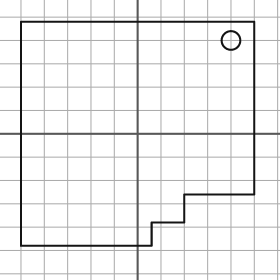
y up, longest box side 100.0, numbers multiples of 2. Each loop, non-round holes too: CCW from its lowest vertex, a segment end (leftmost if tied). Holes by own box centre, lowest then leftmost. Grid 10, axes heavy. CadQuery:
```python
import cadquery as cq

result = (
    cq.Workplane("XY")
    .moveTo(-50.0, -48.0)
    .lineTo(6.0, -48.0)
    .lineTo(6.0, -38.0)
    .lineTo(20.0, -38.0)
    .lineTo(20.0, -26.0)
    .lineTo(50.0, -26.0)
    .lineTo(50.0, 48.0)
    .lineTo(-50.0, 48.0)
    .close()
    .moveTo(40.0, 40.0)
    .circle(4.0)
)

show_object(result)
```